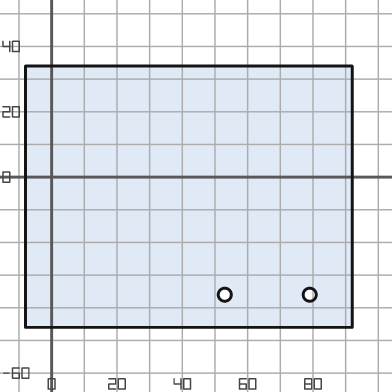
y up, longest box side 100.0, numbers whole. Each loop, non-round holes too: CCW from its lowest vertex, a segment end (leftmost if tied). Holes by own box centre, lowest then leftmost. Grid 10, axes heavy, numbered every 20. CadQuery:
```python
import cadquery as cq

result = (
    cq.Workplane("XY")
    .moveTo(-8.0, -46.0)
    .lineTo(92.0, -46.0)
    .lineTo(92.0, 34.0)
    .lineTo(-8.0, 34.0)
    .close()
    .moveTo(53.0, -36.0)
    .circle(2.0)
    .moveTo(79.0, -36.0)
    .circle(2.0)
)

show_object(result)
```